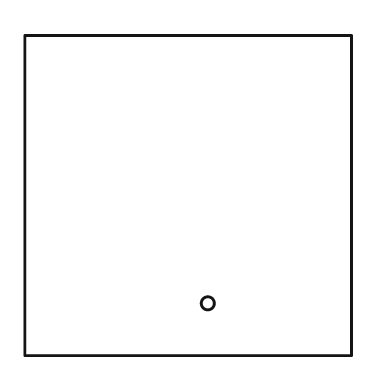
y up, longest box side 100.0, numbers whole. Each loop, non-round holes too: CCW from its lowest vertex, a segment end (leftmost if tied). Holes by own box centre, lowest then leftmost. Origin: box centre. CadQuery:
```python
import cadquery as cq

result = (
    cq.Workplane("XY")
    .moveTo(-50.0, -49.0)
    .lineTo(50.0, -49.0)
    .lineTo(50.0, 49.0)
    .lineTo(-50.0, 49.0)
    .close()
    .moveTo(6.0, -33.0)
    .circle(2.0)
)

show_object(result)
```